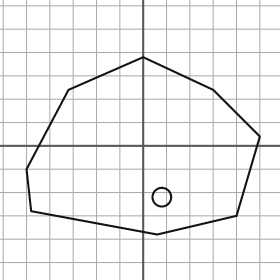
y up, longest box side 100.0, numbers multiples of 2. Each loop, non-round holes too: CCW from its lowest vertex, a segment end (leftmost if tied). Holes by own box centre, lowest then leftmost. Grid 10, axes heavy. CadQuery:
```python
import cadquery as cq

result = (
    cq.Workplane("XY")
    .moveTo(6.0, -38.0)
    .lineTo(40.0, -30.0)
    .lineTo(50.0, 4.0)
    .lineTo(30.0, 24.0)
    .lineTo(0.0, 38.0)
    .lineTo(-32.0, 24.0)
    .lineTo(-50.0, -10.0)
    .lineTo(-48.0, -28.0)
    .close()
    .moveTo(8.0, -22.0)
    .circle(4.0)
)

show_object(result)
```